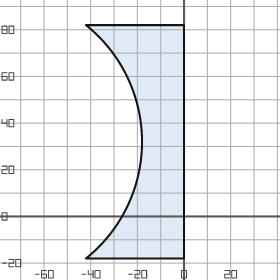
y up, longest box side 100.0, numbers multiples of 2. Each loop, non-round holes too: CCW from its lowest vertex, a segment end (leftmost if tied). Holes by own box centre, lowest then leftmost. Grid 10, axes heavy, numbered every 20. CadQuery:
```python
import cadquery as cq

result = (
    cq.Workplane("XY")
    .moveTo(-42.0, -18.0)
    .lineTo(0.0, -18.0)
    .lineTo(0.0, 82.0)
    .lineTo(-42.0, 82.0)
    .threePointArc((-18.0, 32.0), (-42.0, -18.0))
    .close()
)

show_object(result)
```